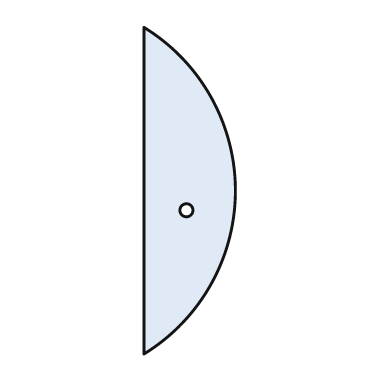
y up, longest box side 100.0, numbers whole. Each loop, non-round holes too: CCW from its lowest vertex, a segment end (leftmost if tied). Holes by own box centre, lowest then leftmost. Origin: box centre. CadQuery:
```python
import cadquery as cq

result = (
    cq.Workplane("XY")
    .moveTo(-14.0, -50.0)
    .threePointArc((14.0, 0.0), (-14.0, 50.0))
    .close()
    .moveTo(-1.0, -6.0)
    .circle(2.0)
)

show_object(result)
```